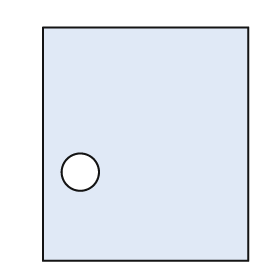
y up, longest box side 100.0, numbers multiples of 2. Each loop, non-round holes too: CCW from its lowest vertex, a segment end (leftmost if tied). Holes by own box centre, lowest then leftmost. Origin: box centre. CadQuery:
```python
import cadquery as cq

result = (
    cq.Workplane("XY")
    .moveTo(-44.0, -50.0)
    .lineTo(44.0, -50.0)
    .lineTo(44.0, 50.0)
    .lineTo(-44.0, 50.0)
    .close()
    .moveTo(-28.0, -12.0)
    .circle(8.0)
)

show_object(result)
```